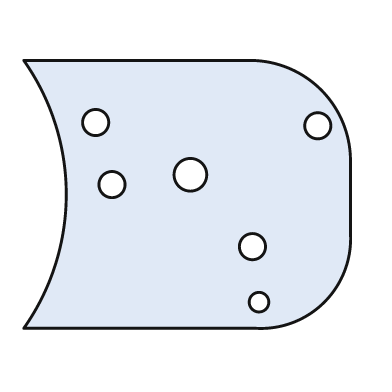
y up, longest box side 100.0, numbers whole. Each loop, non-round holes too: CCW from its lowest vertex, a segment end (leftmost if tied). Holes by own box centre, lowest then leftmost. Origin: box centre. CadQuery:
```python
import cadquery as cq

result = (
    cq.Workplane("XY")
    .moveTo(-50.0, -41.0)
    .lineTo(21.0, -41.0)
    .threePointArc((42.0, -33.0), (50.0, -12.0))
    .lineTo(50.0, 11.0)
    .threePointArc((41.0, 32.0), (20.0, 41.0))
    .lineTo(-50.0, 41.0)
    .threePointArc((-37.0, 0.0), (-50.0, -41.0))
    .close()
    .moveTo(22.0, -33.0)
    .circle(3.0)
    .moveTo(20.0, -16.0)
    .circle(4.0)
    .moveTo(-23.0, 3.0)
    .circle(4.0)
    .moveTo(1.0, 6.0)
    .circle(5.0)
    .moveTo(40.0, 21.0)
    .circle(4.0)
    .moveTo(-28.0, 22.0)
    .circle(4.0)
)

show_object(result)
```